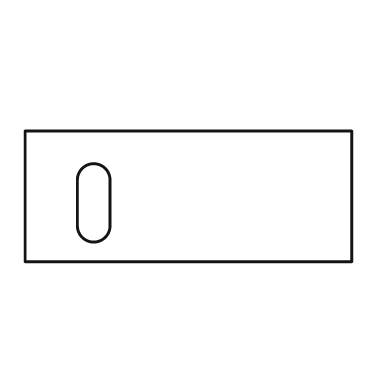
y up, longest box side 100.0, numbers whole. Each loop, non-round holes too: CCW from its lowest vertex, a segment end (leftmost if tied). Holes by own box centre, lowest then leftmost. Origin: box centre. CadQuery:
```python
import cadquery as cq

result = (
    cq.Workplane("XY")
    .moveTo(-50.0, -20.0)
    .lineTo(50.0, -20.0)
    .lineTo(50.0, 20.0)
    .lineTo(-50.0, 20.0)
    .close()
    .moveTo(-34.0, -9.0)
    .threePointArc((-29.0, -14.0), (-24.0, -9.0))
    .lineTo(-24.0, 5.0)
    .threePointArc((-29.0, 10.0), (-34.0, 5.0))
    .close()
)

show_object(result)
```